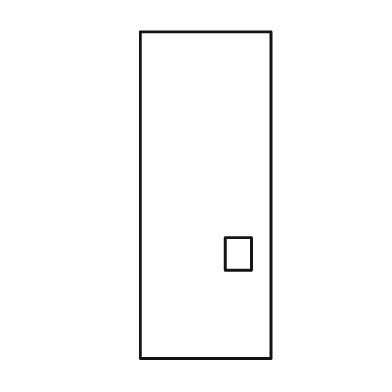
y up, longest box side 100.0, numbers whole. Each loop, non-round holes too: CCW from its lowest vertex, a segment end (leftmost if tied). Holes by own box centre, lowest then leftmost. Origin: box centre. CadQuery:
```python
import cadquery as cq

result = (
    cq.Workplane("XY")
    .moveTo(-20.0, -50.0)
    .lineTo(20.0, -50.0)
    .lineTo(20.0, 50.0)
    .lineTo(-20.0, 50.0)
    .close()
    .moveTo(6.0, -23.0)
    .lineTo(14.0, -23.0)
    .lineTo(14.0, -13.0)
    .lineTo(6.0, -13.0)
    .close()
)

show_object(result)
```